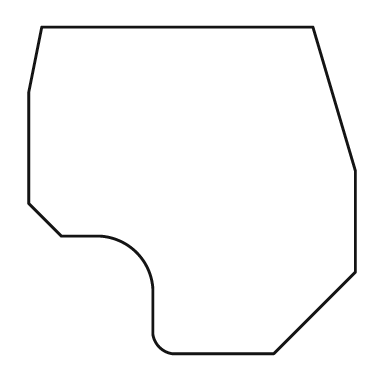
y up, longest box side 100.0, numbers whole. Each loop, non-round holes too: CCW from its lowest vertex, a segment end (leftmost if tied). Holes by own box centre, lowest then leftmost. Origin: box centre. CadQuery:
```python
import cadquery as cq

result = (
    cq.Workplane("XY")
    .moveTo(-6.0, -50.0)
    .lineTo(25.0, -50.0)
    .lineTo(50.0, -25.0)
    .lineTo(50.0, 6.0)
    .lineTo(37.0, 50.0)
    .lineTo(-46.0, 50.0)
    .lineTo(-50.0, 30.0)
    .lineTo(-50.0, -4.0)
    .lineTo(-40.0, -14.0)
    .lineTo(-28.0, -14.0)
    .threePointArc((-17.0, -19.0), (-12.0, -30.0))
    .lineTo(-12.0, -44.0)
    .threePointArc((-10.0, -48.0), (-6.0, -50.0))
    .close()
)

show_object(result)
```